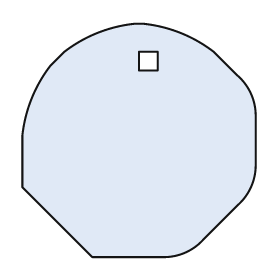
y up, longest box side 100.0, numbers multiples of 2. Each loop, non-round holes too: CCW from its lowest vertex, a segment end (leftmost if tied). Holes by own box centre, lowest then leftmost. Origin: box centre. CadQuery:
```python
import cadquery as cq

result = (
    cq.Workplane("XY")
    .moveTo(-20.0, -50.0)
    .lineTo(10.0, -50.0)
    .threePointArc((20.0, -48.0), (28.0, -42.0))
    .lineTo(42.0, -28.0)
    .threePointArc((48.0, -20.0), (50.0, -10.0))
    .lineTo(50.0, 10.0)
    .threePointArc((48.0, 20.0), (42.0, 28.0))
    .lineTo(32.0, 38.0)
    .threePointArc((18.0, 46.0), (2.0, 50.0))
    .lineTo(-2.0, 50.0)
    .threePointArc((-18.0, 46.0), (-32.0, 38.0))
    .lineTo(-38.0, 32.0)
    .threePointArc((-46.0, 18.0), (-50.0, 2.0))
    .lineTo(-50.0, -20.0)
    .close()
    .moveTo(0.0, 30.0)
    .lineTo(8.0, 30.0)
    .lineTo(8.0, 38.0)
    .lineTo(0.0, 38.0)
    .close()
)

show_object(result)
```